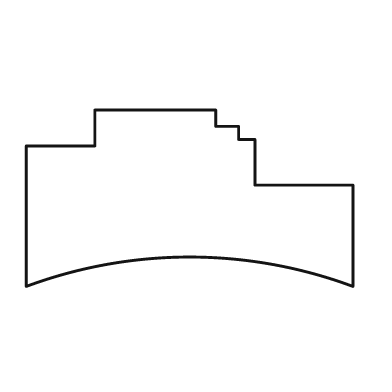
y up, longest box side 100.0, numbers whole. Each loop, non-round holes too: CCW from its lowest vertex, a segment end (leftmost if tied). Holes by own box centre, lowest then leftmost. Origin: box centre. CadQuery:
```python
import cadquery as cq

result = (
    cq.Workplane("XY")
    .moveTo(-50.0, -27.0)
    .threePointArc((0.0, -18.0), (50.0, -27.0))
    .lineTo(50.0, 4.0)
    .lineTo(20.0, 4.0)
    .lineTo(20.0, 18.0)
    .lineTo(15.0, 18.0)
    .lineTo(15.0, 22.0)
    .lineTo(8.0, 22.0)
    .lineTo(8.0, 27.0)
    .lineTo(-29.0, 27.0)
    .lineTo(-29.0, 16.0)
    .lineTo(-50.0, 16.0)
    .close()
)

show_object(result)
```